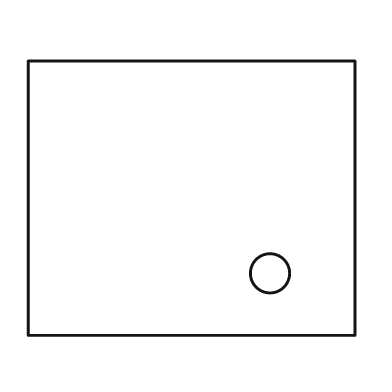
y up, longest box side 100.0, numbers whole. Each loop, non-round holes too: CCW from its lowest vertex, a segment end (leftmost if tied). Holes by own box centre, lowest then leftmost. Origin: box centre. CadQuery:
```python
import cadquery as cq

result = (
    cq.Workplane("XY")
    .moveTo(-50.0, -42.0)
    .lineTo(50.0, -42.0)
    .lineTo(50.0, 42.0)
    .lineTo(-50.0, 42.0)
    .close()
    .moveTo(24.0, -23.0)
    .circle(6.0)
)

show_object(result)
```